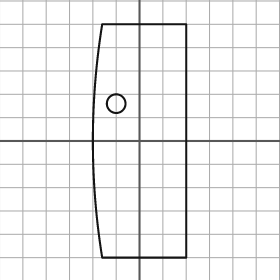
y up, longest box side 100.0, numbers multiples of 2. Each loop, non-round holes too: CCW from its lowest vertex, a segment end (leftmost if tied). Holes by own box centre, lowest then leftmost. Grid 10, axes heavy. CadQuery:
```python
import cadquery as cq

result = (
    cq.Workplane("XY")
    .moveTo(-16.0, -50.0)
    .lineTo(20.0, -50.0)
    .lineTo(20.0, 50.0)
    .lineTo(-16.0, 50.0)
    .threePointArc((-20.0, 0.0), (-16.0, -50.0))
    .close()
    .moveTo(-10.0, 16.0)
    .circle(4.0)
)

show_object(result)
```